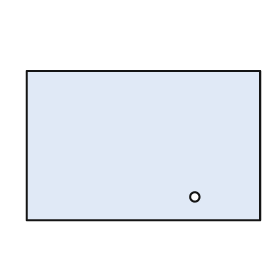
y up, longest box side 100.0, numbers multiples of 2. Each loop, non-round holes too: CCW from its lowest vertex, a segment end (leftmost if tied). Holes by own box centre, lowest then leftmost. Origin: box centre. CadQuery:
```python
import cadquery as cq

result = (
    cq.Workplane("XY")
    .moveTo(-50.0, -32.0)
    .lineTo(50.0, -32.0)
    .lineTo(50.0, 32.0)
    .lineTo(-50.0, 32.0)
    .close()
    .moveTo(22.0, -22.0)
    .circle(2.0)
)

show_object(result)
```